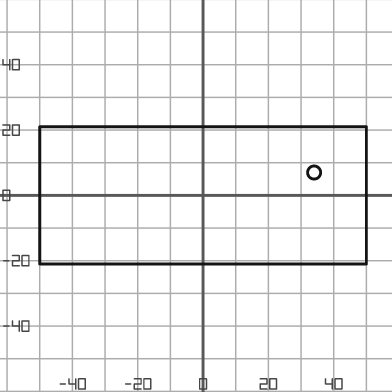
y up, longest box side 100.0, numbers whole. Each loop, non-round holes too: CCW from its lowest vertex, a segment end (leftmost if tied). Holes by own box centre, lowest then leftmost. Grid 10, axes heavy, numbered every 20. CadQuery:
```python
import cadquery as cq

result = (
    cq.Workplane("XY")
    .moveTo(-50.0, -21.0)
    .lineTo(50.0, -21.0)
    .lineTo(50.0, 21.0)
    .lineTo(-50.0, 21.0)
    .close()
    .moveTo(34.0, 7.0)
    .circle(2.0)
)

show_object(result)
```